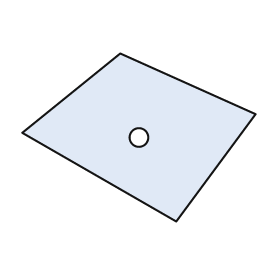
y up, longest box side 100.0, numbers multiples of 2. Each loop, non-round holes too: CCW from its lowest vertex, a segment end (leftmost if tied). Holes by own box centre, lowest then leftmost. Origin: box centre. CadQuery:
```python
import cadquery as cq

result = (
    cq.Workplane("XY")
    .moveTo(16.0, -36.0)
    .lineTo(50.0, 10.0)
    .lineTo(-8.0, 36.0)
    .lineTo(-50.0, 2.0)
    .close()
    .moveTo(0.0, 0.0)
    .circle(4.0)
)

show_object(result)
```